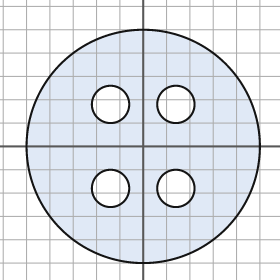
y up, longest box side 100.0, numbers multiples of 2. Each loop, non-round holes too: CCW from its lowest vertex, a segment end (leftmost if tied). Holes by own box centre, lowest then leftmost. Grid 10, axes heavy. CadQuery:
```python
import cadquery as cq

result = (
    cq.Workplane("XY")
    .moveTo(0.0, 0.0)
    .circle(50.0)
    .moveTo(-14.0, -18.0)
    .circle(8.0)
    .moveTo(14.0, -18.0)
    .circle(8.0)
    .moveTo(-14.0, 18.0)
    .circle(8.0)
    .moveTo(14.0, 18.0)
    .circle(8.0)
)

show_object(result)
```